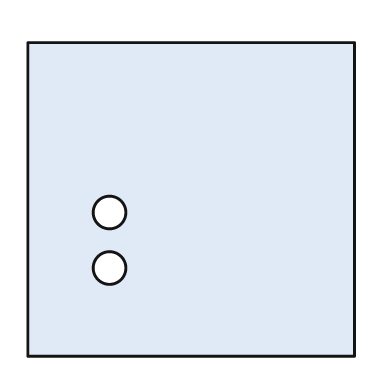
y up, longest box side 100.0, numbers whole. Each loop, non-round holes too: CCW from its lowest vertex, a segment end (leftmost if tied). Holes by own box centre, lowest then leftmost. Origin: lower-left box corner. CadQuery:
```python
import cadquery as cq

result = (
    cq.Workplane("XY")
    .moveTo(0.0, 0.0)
    .lineTo(100.0, 0.0)
    .lineTo(100.0, 96.0)
    .lineTo(0.0, 96.0)
    .close()
    .moveTo(25.0, 27.0)
    .circle(5.0)
    .moveTo(25.0, 44.0)
    .circle(5.0)
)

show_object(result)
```